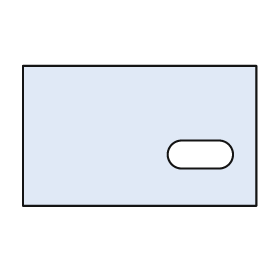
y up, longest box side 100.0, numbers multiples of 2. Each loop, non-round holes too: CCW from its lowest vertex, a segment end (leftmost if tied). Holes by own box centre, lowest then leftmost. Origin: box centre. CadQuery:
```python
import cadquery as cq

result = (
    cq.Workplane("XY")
    .moveTo(-50.0, -30.0)
    .lineTo(50.0, -30.0)
    .lineTo(50.0, 30.0)
    .lineTo(-50.0, 30.0)
    .close()
    .moveTo(18.0, -14.0)
    .lineTo(34.0, -14.0)
    .threePointArc((40.0, -8.0), (34.0, -2.0))
    .lineTo(18.0, -2.0)
    .threePointArc((12.0, -8.0), (18.0, -14.0))
    .close()
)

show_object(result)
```